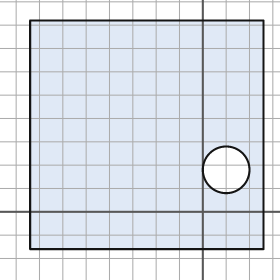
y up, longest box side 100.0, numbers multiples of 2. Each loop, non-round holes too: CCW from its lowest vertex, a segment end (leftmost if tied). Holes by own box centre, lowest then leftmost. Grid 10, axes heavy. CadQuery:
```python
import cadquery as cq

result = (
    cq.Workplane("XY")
    .moveTo(-74.0, -16.0)
    .lineTo(26.0, -16.0)
    .lineTo(26.0, 82.0)
    .lineTo(-74.0, 82.0)
    .close()
    .moveTo(10.0, 18.0)
    .circle(10.0)
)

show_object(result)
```